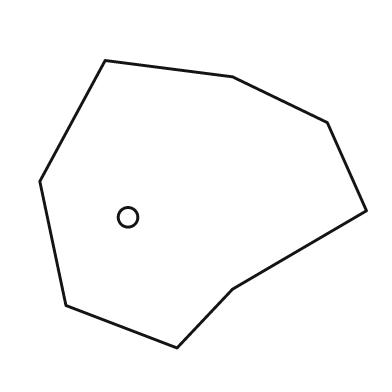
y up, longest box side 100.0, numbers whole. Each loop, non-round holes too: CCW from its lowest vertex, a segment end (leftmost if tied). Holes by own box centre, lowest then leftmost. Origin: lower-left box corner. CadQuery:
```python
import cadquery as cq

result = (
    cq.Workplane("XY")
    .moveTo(42.0, 0.0)
    .lineTo(59.0, 18.0)
    .lineTo(100.0, 42.0)
    .lineTo(88.0, 69.0)
    .lineTo(59.0, 83.0)
    .lineTo(20.0, 88.0)
    .lineTo(0.0, 51.0)
    .lineTo(8.0, 13.0)
    .close()
    .moveTo(27.0, 40.0)
    .circle(3.0)
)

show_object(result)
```